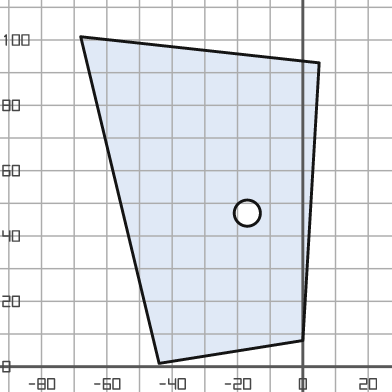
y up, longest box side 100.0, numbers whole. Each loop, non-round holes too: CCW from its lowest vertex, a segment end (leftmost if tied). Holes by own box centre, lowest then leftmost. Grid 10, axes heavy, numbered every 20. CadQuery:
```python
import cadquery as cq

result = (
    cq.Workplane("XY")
    .moveTo(-44.0, 1.0)
    .lineTo(0.0, 8.0)
    .lineTo(5.0, 93.0)
    .lineTo(-68.0, 101.0)
    .close()
    .moveTo(-17.0, 47.0)
    .circle(4.0)
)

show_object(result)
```